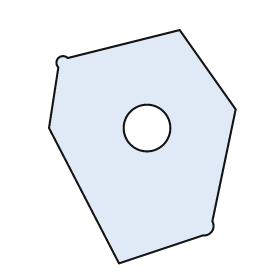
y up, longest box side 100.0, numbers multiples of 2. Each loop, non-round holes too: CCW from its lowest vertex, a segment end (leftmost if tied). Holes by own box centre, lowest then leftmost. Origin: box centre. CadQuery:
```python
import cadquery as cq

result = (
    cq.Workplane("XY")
    .moveTo(-10.0, -50.0)
    .lineTo(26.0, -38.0)
    .threePointArc((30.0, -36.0), (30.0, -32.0))
    .lineTo(40.0, 16.0)
    .lineTo(16.0, 50.0)
    .lineTo(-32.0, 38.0)
    .threePointArc((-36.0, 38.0), (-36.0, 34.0))
    .lineTo(-40.0, 8.0)
    .close()
    .moveTo(2.0, 8.0)
    .circle(10.0)
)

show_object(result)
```